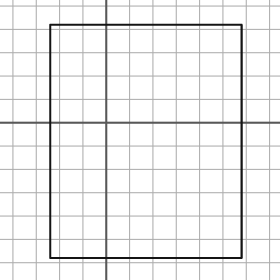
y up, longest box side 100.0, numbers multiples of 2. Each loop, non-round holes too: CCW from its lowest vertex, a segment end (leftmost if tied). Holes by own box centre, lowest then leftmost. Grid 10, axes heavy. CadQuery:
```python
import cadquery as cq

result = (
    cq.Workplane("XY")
    .moveTo(-24.0, -58.0)
    .lineTo(58.0, -58.0)
    .lineTo(58.0, 42.0)
    .lineTo(-24.0, 42.0)
    .close()
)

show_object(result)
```